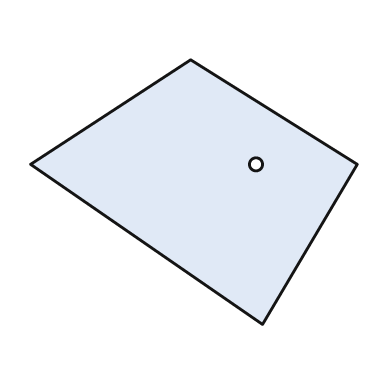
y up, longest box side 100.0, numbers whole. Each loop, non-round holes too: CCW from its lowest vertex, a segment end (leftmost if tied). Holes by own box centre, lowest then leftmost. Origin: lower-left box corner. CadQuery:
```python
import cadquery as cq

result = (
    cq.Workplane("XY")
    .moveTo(71.0, 0.0)
    .lineTo(100.0, 49.0)
    .lineTo(49.0, 81.0)
    .lineTo(0.0, 49.0)
    .close()
    .moveTo(69.0, 49.0)
    .circle(2.0)
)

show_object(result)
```